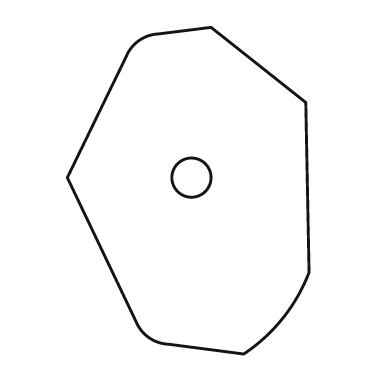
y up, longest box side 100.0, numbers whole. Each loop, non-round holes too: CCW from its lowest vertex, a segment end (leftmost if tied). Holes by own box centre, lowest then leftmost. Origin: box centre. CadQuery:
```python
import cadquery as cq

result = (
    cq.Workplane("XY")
    .moveTo(17.0, -50.0)
    .threePointArc((29.0, -39.0), (37.0, -25.0))
    .lineTo(36.0, 27.0)
    .lineTo(7.0, 50.0)
    .lineTo(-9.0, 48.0)
    .threePointArc((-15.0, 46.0), (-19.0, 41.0))
    .lineTo(-37.0, 4.0)
    .lineTo(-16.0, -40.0)
    .threePointArc((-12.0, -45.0), (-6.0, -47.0))
    .close()
    .moveTo(1.0, 4.0)
    .circle(6.0)
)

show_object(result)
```